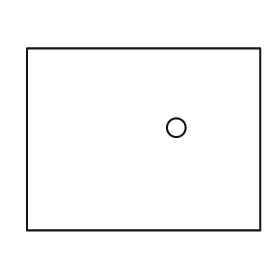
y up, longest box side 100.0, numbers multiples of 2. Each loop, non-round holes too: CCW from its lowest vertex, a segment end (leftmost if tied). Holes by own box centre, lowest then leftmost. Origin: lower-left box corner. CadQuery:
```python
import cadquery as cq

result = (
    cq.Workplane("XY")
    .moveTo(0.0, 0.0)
    .lineTo(100.0, 0.0)
    .lineTo(100.0, 78.0)
    .lineTo(0.0, 78.0)
    .close()
    .moveTo(64.0, 44.0)
    .circle(4.0)
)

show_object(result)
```